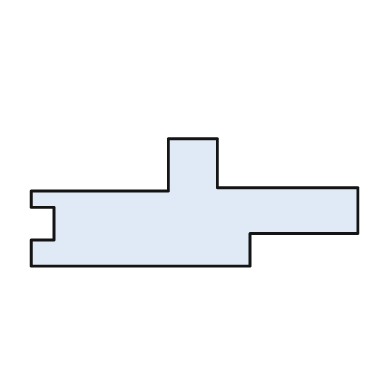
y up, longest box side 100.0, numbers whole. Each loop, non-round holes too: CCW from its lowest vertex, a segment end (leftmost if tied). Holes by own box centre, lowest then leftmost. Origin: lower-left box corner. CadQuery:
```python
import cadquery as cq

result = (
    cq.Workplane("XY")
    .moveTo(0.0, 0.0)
    .lineTo(67.0, 0.0)
    .lineTo(67.0, 10.0)
    .lineTo(100.0, 10.0)
    .lineTo(100.0, 24.0)
    .lineTo(57.0, 24.0)
    .lineTo(57.0, 39.0)
    .lineTo(42.0, 39.0)
    .lineTo(42.0, 23.0)
    .lineTo(0.0, 23.0)
    .lineTo(0.0, 18.0)
    .lineTo(7.0, 18.0)
    .lineTo(7.0, 8.0)
    .lineTo(0.0, 8.0)
    .close()
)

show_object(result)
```